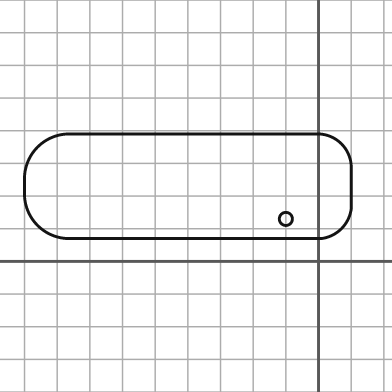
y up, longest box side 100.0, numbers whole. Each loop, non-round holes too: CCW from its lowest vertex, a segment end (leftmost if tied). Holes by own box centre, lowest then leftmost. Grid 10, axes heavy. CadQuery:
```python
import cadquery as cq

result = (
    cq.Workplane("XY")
    .moveTo(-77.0, 7.0)
    .lineTo(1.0, 7.0)
    .threePointArc((7.0, 10.0), (10.0, 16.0))
    .lineTo(10.0, 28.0)
    .threePointArc((7.0, 36.0), (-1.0, 39.0))
    .lineTo(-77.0, 39.0)
    .threePointArc((-86.0, 35.0), (-90.0, 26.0))
    .lineTo(-90.0, 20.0)
    .threePointArc((-86.0, 11.0), (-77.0, 7.0))
    .close()
    .moveTo(-10.0, 13.0)
    .circle(2.0)
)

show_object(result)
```